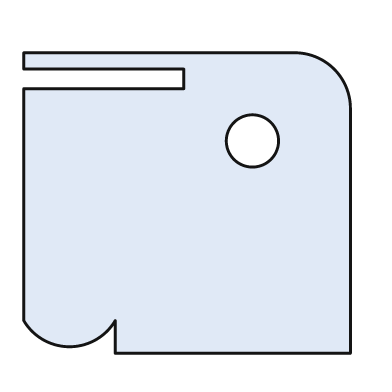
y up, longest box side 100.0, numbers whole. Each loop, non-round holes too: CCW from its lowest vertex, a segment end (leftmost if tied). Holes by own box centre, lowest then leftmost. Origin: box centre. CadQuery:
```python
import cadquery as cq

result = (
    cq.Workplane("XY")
    .moveTo(-22.0, -46.0)
    .lineTo(50.0, -46.0)
    .lineTo(50.0, 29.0)
    .threePointArc((45.0, 41.0), (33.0, 46.0))
    .lineTo(-50.0, 46.0)
    .lineTo(-50.0, 41.0)
    .lineTo(-1.0, 41.0)
    .lineTo(-1.0, 35.0)
    .lineTo(-50.0, 35.0)
    .lineTo(-50.0, -36.0)
    .threePointArc((-36.0, -44.0), (-22.0, -36.0))
    .close()
    .moveTo(20.0, 19.0)
    .circle(8.0)
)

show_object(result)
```